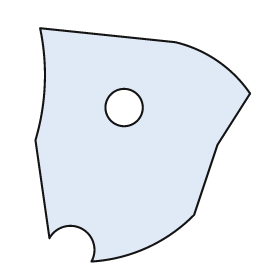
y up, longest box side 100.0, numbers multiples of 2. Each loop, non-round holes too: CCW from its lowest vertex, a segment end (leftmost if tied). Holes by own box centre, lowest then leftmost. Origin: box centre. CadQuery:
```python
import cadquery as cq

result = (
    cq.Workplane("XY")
    .moveTo(-22.0, -50.0)
    .threePointArc((2.0, -44.0), (22.0, -30.0))
    .lineTo(32.0, 0.0)
    .lineTo(46.0, 22.0)
    .threePointArc((32.0, 36.0), (14.0, 44.0))
    .lineTo(-44.0, 50.0)
    .threePointArc((-42.0, 26.0), (-46.0, 2.0))
    .lineTo(-40.0, -40.0)
    .threePointArc((-26.0, -36.0), (-22.0, -50.0))
    .close()
    .moveTo(-8.0, 16.0)
    .circle(8.0)
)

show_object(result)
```